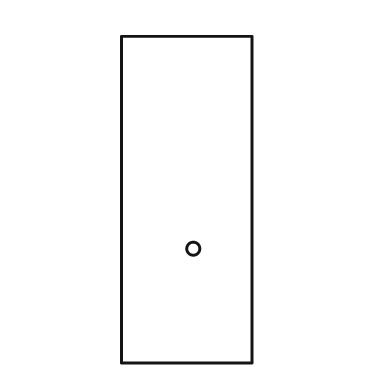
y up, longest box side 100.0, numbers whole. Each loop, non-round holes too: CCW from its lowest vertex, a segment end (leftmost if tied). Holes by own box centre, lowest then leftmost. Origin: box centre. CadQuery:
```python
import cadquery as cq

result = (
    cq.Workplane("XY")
    .moveTo(-20.0, -50.0)
    .lineTo(20.0, -50.0)
    .lineTo(20.0, 50.0)
    .lineTo(-20.0, 50.0)
    .close()
    .moveTo(2.0, -15.0)
    .circle(2.0)
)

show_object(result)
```